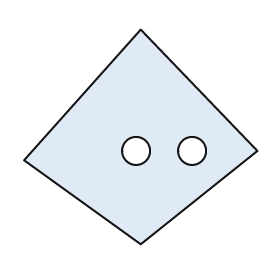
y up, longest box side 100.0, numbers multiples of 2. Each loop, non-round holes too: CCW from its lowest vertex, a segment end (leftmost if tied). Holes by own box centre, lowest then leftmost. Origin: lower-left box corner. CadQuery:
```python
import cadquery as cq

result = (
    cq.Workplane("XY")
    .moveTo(50.0, 0.0)
    .lineTo(100.0, 40.0)
    .lineTo(50.0, 92.0)
    .lineTo(0.0, 36.0)
    .close()
    .moveTo(48.0, 40.0)
    .circle(6.0)
    .moveTo(72.0, 40.0)
    .circle(6.0)
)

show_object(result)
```